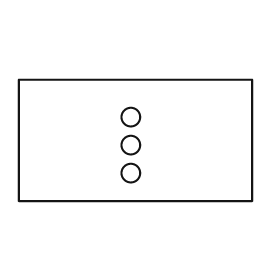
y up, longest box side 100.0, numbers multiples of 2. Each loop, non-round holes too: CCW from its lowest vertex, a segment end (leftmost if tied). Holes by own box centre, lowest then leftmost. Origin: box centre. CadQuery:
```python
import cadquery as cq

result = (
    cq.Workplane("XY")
    .moveTo(-50.0, -26.0)
    .lineTo(50.0, -26.0)
    .lineTo(50.0, 26.0)
    .lineTo(-50.0, 26.0)
    .close()
    .moveTo(-2.0, -14.0)
    .circle(4.0)
    .moveTo(-2.0, -2.0)
    .circle(4.0)
    .moveTo(-2.0, 10.0)
    .circle(4.0)
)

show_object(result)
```